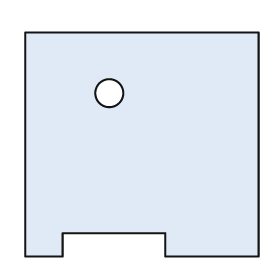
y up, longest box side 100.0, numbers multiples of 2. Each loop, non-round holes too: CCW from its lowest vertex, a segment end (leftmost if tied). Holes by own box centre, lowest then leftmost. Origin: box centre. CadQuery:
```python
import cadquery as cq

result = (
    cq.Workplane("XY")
    .moveTo(-50.0, -48.0)
    .lineTo(-34.0, -48.0)
    .lineTo(-34.0, -38.0)
    .lineTo(10.0, -38.0)
    .lineTo(10.0, -48.0)
    .lineTo(50.0, -48.0)
    .lineTo(50.0, 48.0)
    .lineTo(-50.0, 48.0)
    .close()
    .moveTo(-14.0, 22.0)
    .circle(6.0)
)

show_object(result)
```